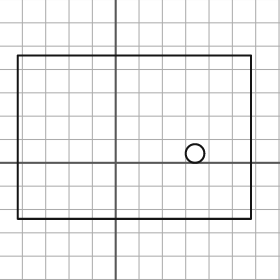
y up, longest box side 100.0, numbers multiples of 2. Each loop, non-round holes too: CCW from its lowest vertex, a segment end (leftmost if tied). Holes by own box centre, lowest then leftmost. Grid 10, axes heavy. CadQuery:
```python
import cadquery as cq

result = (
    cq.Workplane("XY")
    .moveTo(-42.0, -24.0)
    .lineTo(58.0, -24.0)
    .lineTo(58.0, 46.0)
    .lineTo(-42.0, 46.0)
    .close()
    .moveTo(34.0, 4.0)
    .circle(4.0)
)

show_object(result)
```